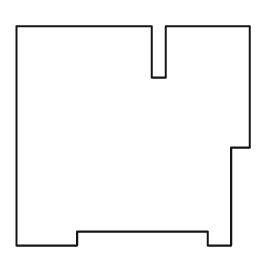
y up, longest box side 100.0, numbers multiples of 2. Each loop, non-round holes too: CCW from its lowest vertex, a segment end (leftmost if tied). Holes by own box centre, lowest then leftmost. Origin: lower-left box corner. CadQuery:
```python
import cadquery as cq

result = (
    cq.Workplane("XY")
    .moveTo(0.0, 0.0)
    .lineTo(26.0, 0.0)
    .lineTo(26.0, 6.0)
    .lineTo(82.0, 6.0)
    .lineTo(82.0, 0.0)
    .lineTo(92.0, 0.0)
    .lineTo(92.0, 42.0)
    .lineTo(100.0, 42.0)
    .lineTo(100.0, 94.0)
    .lineTo(64.0, 94.0)
    .lineTo(64.0, 72.0)
    .lineTo(58.0, 72.0)
    .lineTo(58.0, 94.0)
    .lineTo(0.0, 94.0)
    .close()
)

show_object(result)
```